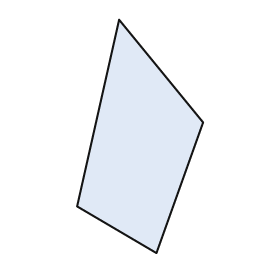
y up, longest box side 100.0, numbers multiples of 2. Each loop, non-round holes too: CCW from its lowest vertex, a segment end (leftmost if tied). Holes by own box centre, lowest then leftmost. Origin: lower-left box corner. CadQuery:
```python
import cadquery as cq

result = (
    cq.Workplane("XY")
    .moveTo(34.0, 0.0)
    .lineTo(54.0, 56.0)
    .lineTo(18.0, 100.0)
    .lineTo(0.0, 20.0)
    .close()
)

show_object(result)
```